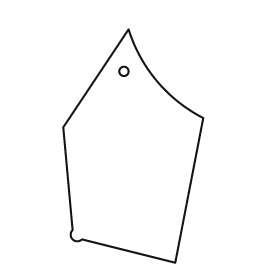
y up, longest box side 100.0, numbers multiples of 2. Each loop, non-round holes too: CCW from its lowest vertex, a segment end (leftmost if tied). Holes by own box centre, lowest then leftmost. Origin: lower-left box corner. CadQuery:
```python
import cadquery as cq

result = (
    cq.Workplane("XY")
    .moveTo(48.0, 0.0)
    .lineTo(60.0, 62.0)
    .threePointArc((40.0, 78.0), (28.0, 100.0))
    .lineTo(0.0, 58.0)
    .lineTo(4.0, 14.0)
    .threePointArc((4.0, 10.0), (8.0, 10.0))
    .close()
    .moveTo(26.0, 82.0)
    .circle(2.0)
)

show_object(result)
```